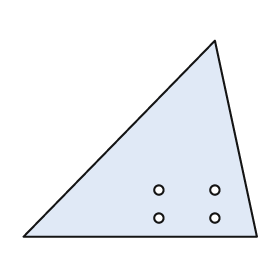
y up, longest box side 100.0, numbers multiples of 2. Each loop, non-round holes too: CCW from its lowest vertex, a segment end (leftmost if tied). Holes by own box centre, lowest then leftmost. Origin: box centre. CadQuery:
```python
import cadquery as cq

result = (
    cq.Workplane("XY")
    .moveTo(-50.0, -42.0)
    .lineTo(50.0, -42.0)
    .lineTo(32.0, 42.0)
    .close()
    .moveTo(8.0, -34.0)
    .circle(2.0)
    .moveTo(32.0, -34.0)
    .circle(2.0)
    .moveTo(8.0, -22.0)
    .circle(2.0)
    .moveTo(32.0, -22.0)
    .circle(2.0)
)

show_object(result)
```